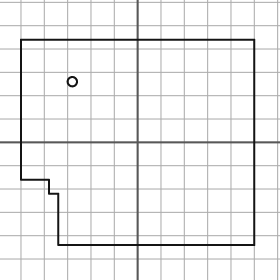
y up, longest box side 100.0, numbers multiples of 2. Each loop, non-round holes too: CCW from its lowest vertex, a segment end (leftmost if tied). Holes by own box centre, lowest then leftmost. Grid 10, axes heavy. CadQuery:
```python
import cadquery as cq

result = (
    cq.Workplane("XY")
    .moveTo(-34.0, -44.0)
    .lineTo(50.0, -44.0)
    .lineTo(50.0, 44.0)
    .lineTo(-50.0, 44.0)
    .lineTo(-50.0, -16.0)
    .lineTo(-38.0, -16.0)
    .lineTo(-38.0, -22.0)
    .lineTo(-34.0, -22.0)
    .close()
    .moveTo(-28.0, 26.0)
    .circle(2.0)
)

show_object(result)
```